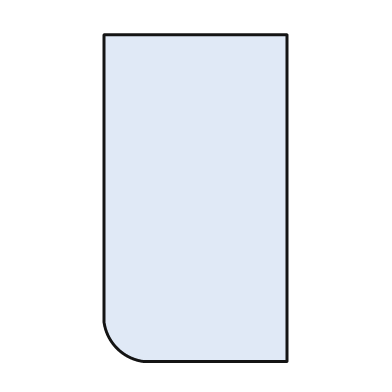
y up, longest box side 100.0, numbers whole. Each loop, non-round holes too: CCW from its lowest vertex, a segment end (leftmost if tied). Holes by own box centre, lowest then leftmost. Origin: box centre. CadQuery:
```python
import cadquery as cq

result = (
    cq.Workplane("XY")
    .moveTo(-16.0, -50.0)
    .lineTo(28.0, -50.0)
    .lineTo(28.0, 50.0)
    .lineTo(-28.0, 50.0)
    .lineTo(-28.0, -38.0)
    .threePointArc((-24.0, -46.0), (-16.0, -50.0))
    .close()
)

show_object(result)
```